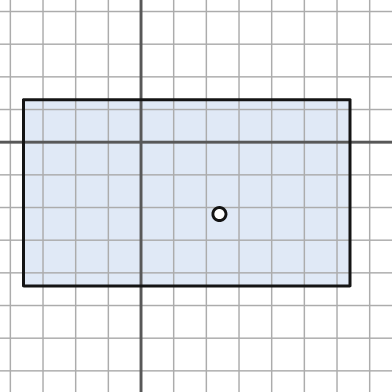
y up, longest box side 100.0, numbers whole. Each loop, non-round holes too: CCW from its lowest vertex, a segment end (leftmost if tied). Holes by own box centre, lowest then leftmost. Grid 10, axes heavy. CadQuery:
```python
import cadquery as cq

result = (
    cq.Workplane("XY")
    .moveTo(-36.0, -44.0)
    .lineTo(64.0, -44.0)
    .lineTo(64.0, 13.0)
    .lineTo(-36.0, 13.0)
    .close()
    .moveTo(24.0, -22.0)
    .circle(2.0)
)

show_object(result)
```